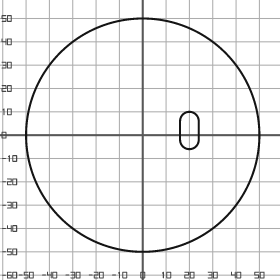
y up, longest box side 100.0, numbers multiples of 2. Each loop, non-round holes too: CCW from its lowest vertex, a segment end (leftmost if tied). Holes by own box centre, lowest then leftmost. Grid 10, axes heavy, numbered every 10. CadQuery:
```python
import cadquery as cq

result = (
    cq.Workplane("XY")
    .moveTo(0.0, 0.0)
    .circle(50.0)
    .moveTo(16.0, -2.0)
    .threePointArc((20.0, -6.0), (24.0, -2.0))
    .lineTo(24.0, 6.0)
    .threePointArc((20.0, 10.0), (16.0, 6.0))
    .close()
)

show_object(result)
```